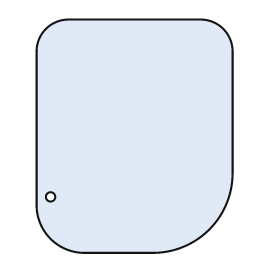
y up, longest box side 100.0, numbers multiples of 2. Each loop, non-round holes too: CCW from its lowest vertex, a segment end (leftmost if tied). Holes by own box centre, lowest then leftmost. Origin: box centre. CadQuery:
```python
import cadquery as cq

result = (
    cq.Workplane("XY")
    .moveTo(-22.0, -50.0)
    .lineTo(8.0, -50.0)
    .threePointArc((32.0, -40.0), (42.0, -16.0))
    .lineTo(42.0, 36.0)
    .threePointArc((38.0, 46.0), (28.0, 50.0))
    .lineTo(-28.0, 50.0)
    .threePointArc((-38.0, 46.0), (-42.0, 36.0))
    .lineTo(-42.0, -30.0)
    .threePointArc((-36.0, -44.0), (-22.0, -50.0))
    .close()
    .moveTo(-36.0, -26.0)
    .circle(2.0)
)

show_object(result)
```